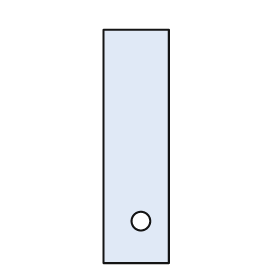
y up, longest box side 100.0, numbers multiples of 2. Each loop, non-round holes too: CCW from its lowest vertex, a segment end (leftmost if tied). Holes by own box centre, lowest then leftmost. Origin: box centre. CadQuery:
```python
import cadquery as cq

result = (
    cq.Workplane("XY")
    .moveTo(-14.0, -50.0)
    .lineTo(14.0, -50.0)
    .lineTo(14.0, 50.0)
    .lineTo(-14.0, 50.0)
    .close()
    .moveTo(2.0, -32.0)
    .circle(4.0)
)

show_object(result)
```